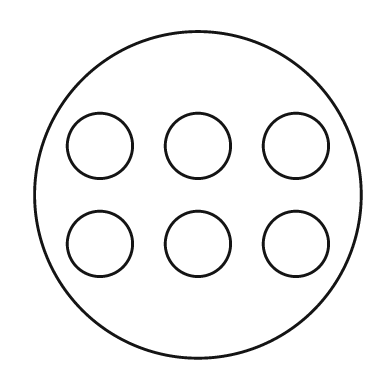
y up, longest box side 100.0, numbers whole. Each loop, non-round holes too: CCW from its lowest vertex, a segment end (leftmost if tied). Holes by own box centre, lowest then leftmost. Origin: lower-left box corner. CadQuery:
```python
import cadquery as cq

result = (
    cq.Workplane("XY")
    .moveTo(50.0, 50.0)
    .circle(50.0)
    .moveTo(20.0, 35.0)
    .circle(10.0)
    .moveTo(50.0, 35.0)
    .circle(10.0)
    .moveTo(80.0, 35.0)
    .circle(10.0)
    .moveTo(20.0, 65.0)
    .circle(10.0)
    .moveTo(50.0, 65.0)
    .circle(10.0)
    .moveTo(80.0, 65.0)
    .circle(10.0)
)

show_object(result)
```